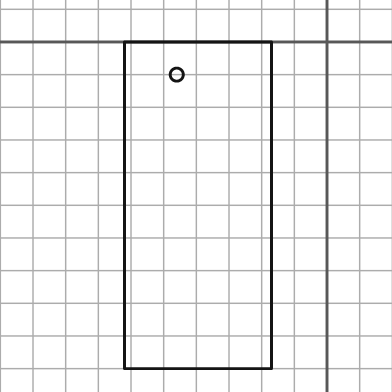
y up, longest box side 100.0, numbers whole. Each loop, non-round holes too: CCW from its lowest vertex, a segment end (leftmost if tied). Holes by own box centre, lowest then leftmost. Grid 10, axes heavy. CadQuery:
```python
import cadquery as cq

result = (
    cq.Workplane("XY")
    .moveTo(-62.0, -100.0)
    .lineTo(-17.0, -100.0)
    .lineTo(-17.0, 0.0)
    .lineTo(-62.0, 0.0)
    .close()
    .moveTo(-46.0, -10.0)
    .circle(2.0)
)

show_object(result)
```